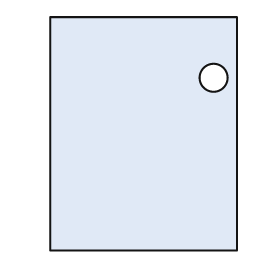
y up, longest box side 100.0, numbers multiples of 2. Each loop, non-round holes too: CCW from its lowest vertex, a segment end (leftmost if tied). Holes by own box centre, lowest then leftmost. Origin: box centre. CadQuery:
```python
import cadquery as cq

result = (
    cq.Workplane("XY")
    .moveTo(-40.0, -50.0)
    .lineTo(40.0, -50.0)
    .lineTo(40.0, 50.0)
    .lineTo(-40.0, 50.0)
    .close()
    .moveTo(30.0, 24.0)
    .circle(6.0)
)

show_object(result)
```